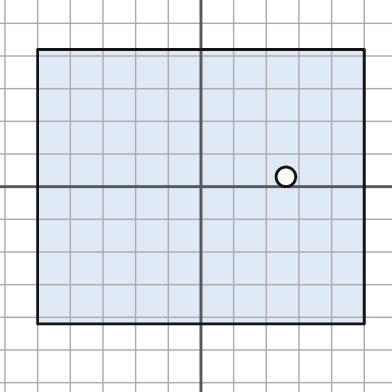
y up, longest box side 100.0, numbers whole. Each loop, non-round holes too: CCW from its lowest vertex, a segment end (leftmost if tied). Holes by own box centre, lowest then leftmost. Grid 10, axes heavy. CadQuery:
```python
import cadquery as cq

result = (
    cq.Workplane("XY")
    .moveTo(-50.0, -42.0)
    .lineTo(50.0, -42.0)
    .lineTo(50.0, 42.0)
    .lineTo(-50.0, 42.0)
    .close()
    .moveTo(26.0, 3.0)
    .circle(3.0)
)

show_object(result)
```